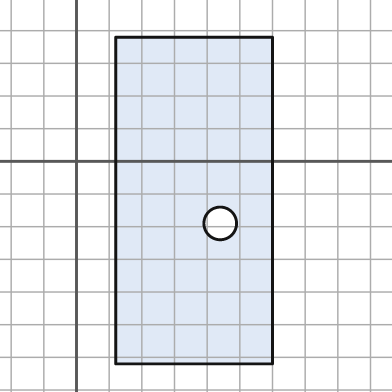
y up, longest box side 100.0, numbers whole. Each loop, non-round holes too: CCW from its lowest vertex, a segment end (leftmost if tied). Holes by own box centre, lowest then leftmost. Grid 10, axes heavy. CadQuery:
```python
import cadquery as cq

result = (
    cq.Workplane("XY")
    .moveTo(12.0, -62.0)
    .lineTo(60.0, -62.0)
    .lineTo(60.0, 38.0)
    .lineTo(12.0, 38.0)
    .close()
    .moveTo(44.0, -19.0)
    .circle(5.0)
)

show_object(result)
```